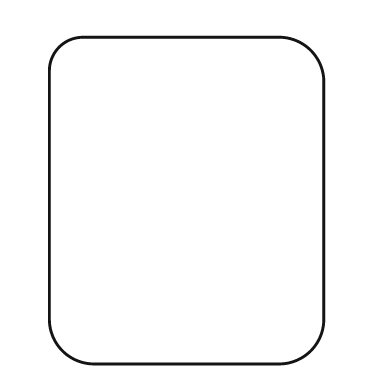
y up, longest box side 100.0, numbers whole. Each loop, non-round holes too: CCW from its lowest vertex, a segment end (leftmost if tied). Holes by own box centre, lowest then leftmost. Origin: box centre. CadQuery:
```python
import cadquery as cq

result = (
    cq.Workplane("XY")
    .moveTo(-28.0, -50.0)
    .lineTo(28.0, -50.0)
    .threePointArc((38.0, -46.0), (42.0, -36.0))
    .lineTo(42.0, 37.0)
    .threePointArc((38.0, 46.0), (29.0, 50.0))
    .lineTo(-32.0, 50.0)
    .threePointArc((-39.0, 47.0), (-42.0, 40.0))
    .lineTo(-42.0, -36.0)
    .threePointArc((-38.0, -46.0), (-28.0, -50.0))
    .close()
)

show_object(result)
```